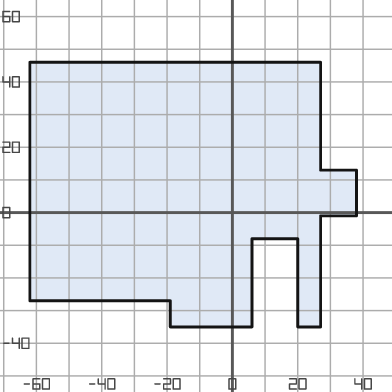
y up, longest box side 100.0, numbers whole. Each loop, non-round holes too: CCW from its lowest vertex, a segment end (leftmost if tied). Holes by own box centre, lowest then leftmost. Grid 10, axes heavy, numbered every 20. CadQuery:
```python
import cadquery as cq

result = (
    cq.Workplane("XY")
    .moveTo(-19.0, -35.0)
    .lineTo(6.0, -35.0)
    .lineTo(6.0, -8.0)
    .lineTo(20.0, -8.0)
    .lineTo(20.0, -35.0)
    .lineTo(27.0, -35.0)
    .lineTo(27.0, -1.0)
    .lineTo(38.0, -1.0)
    .lineTo(38.0, 13.0)
    .lineTo(27.0, 13.0)
    .lineTo(27.0, 46.0)
    .lineTo(-62.0, 46.0)
    .lineTo(-62.0, -27.0)
    .lineTo(-19.0, -27.0)
    .close()
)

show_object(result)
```